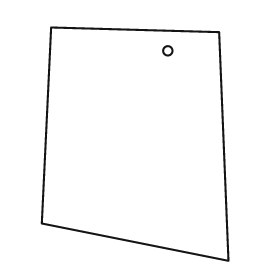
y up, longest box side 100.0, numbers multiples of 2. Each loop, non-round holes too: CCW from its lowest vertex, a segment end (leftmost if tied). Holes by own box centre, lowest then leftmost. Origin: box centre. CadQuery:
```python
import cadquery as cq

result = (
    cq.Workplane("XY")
    .moveTo(40.0, -50.0)
    .lineTo(36.0, 48.0)
    .lineTo(-36.0, 50.0)
    .lineTo(-40.0, -34.0)
    .close()
    .moveTo(14.0, 40.0)
    .circle(2.0)
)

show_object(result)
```